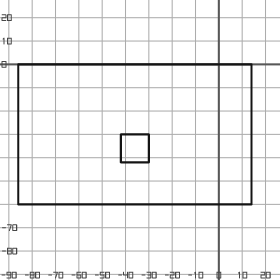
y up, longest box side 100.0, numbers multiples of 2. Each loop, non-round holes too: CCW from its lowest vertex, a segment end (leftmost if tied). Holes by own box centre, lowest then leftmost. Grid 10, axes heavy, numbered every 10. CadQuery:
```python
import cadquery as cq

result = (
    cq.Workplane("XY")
    .moveTo(-86.0, -60.0)
    .lineTo(14.0, -60.0)
    .lineTo(14.0, 0.0)
    .lineTo(-86.0, 0.0)
    .close()
    .moveTo(-42.0, -42.0)
    .lineTo(-30.0, -42.0)
    .lineTo(-30.0, -30.0)
    .lineTo(-42.0, -30.0)
    .close()
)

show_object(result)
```